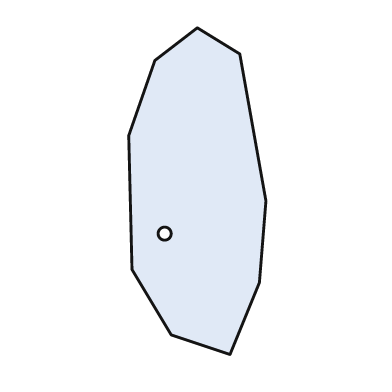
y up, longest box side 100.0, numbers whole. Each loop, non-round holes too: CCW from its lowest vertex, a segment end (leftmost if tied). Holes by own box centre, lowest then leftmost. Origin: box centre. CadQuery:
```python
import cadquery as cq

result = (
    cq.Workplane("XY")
    .moveTo(10.0, -50.0)
    .lineTo(19.0, -28.0)
    .lineTo(21.0, -3.0)
    .lineTo(13.0, 42.0)
    .lineTo(0.0, 50.0)
    .lineTo(-13.0, 40.0)
    .lineTo(-21.0, 17.0)
    .lineTo(-20.0, -24.0)
    .lineTo(-8.0, -44.0)
    .close()
    .moveTo(-10.0, -13.0)
    .circle(2.0)
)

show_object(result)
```